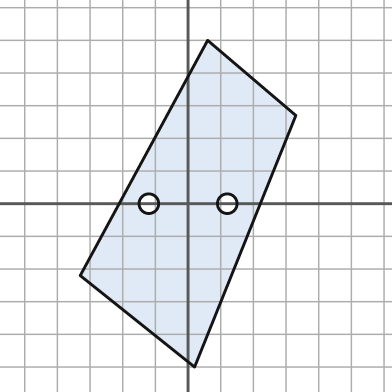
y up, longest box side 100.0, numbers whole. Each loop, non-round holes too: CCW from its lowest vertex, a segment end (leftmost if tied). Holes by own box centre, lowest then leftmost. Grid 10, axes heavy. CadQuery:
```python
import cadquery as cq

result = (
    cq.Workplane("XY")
    .moveTo(2.0, -50.0)
    .lineTo(33.0, 27.0)
    .lineTo(6.0, 50.0)
    .lineTo(-33.0, -22.0)
    .close()
    .moveTo(-12.0, 0.0)
    .circle(3.0)
    .moveTo(12.0, 0.0)
    .circle(3.0)
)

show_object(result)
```